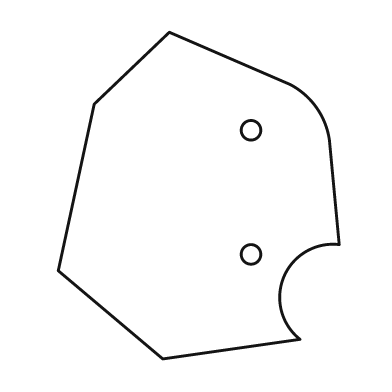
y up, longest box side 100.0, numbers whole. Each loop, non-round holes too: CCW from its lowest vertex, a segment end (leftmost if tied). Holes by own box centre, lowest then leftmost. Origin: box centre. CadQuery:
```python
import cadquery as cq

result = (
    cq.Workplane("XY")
    .moveTo(-11.0, -50.0)
    .lineTo(31.0, -44.0)
    .threePointArc((26.0, -25.0), (43.0, -15.0))
    .lineTo(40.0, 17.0)
    .threePointArc((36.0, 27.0), (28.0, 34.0))
    .lineTo(-9.0, 50.0)
    .lineTo(-32.0, 28.0)
    .lineTo(-43.0, -23.0)
    .close()
    .moveTo(16.0, -18.0)
    .circle(3.0)
    .moveTo(16.0, 20.0)
    .circle(3.0)
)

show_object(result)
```